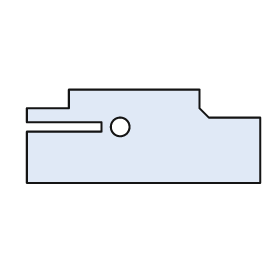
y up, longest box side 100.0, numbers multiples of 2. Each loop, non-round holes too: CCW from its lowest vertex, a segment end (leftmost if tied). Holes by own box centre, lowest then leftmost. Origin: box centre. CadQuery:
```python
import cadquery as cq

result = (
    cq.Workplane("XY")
    .moveTo(-50.0, -20.0)
    .lineTo(50.0, -20.0)
    .lineTo(50.0, 8.0)
    .lineTo(28.0, 8.0)
    .lineTo(24.0, 12.0)
    .lineTo(24.0, 20.0)
    .lineTo(-32.0, 20.0)
    .lineTo(-32.0, 12.0)
    .lineTo(-50.0, 12.0)
    .lineTo(-50.0, 6.0)
    .lineTo(-18.0, 6.0)
    .lineTo(-18.0, 2.0)
    .lineTo(-50.0, 2.0)
    .close()
    .moveTo(-10.0, 4.0)
    .circle(4.0)
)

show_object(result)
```